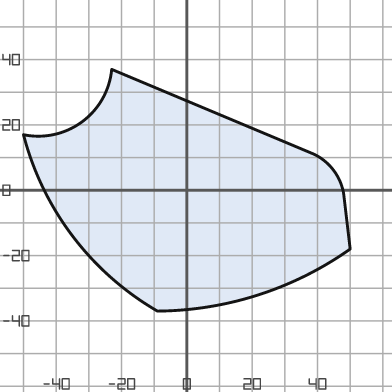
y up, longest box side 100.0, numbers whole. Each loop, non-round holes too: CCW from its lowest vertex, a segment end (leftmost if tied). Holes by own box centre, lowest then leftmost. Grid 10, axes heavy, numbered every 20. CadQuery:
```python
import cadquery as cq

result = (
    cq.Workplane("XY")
    .moveTo(-9.0, -37.0)
    .threePointArc((22.0, -32.0), (50.0, -18.0))
    .lineTo(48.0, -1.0)
    .threePointArc((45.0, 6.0), (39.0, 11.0))
    .lineTo(-23.0, 37.0)
    .threePointArc((-32.0, 21.0), (-50.0, 17.0))
    .threePointArc((-35.0, -14.0), (-9.0, -37.0))
    .close()
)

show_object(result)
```